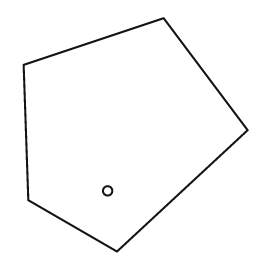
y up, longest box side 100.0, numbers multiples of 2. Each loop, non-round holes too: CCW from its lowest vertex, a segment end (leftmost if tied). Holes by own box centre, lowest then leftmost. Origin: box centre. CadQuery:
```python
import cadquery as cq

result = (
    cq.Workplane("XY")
    .moveTo(-8.0, -50.0)
    .lineTo(48.0, 2.0)
    .lineTo(12.0, 50.0)
    .lineTo(-48.0, 30.0)
    .lineTo(-46.0, -28.0)
    .close()
    .moveTo(-12.0, -24.0)
    .circle(2.0)
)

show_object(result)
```